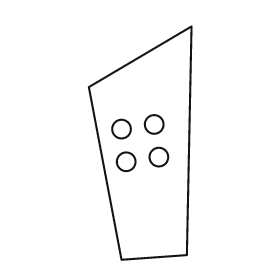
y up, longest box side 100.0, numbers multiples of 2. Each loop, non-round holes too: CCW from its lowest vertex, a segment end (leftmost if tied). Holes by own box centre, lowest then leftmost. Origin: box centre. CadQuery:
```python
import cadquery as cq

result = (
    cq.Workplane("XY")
    .moveTo(-8.0, -50.0)
    .lineTo(20.0, -48.0)
    .lineTo(22.0, 50.0)
    .lineTo(-22.0, 24.0)
    .close()
    .moveTo(-6.0, -8.0)
    .circle(4.0)
    .moveTo(8.0, -6.0)
    .circle(4.0)
    .moveTo(-8.0, 6.0)
    .circle(4.0)
    .moveTo(6.0, 8.0)
    .circle(4.0)
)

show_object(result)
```